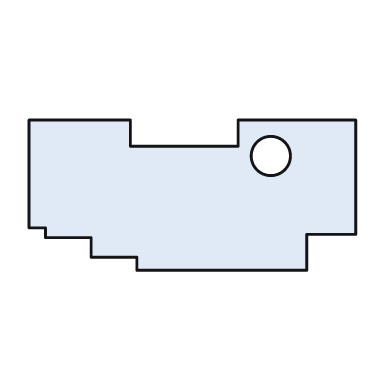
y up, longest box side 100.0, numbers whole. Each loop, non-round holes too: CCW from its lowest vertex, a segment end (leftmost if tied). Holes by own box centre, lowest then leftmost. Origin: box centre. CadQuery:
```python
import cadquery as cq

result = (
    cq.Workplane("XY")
    .moveTo(-17.0, -23.0)
    .lineTo(35.0, -23.0)
    .lineTo(35.0, -12.0)
    .lineTo(50.0, -12.0)
    .lineTo(50.0, 23.0)
    .lineTo(14.0, 23.0)
    .lineTo(14.0, 15.0)
    .lineTo(-19.0, 15.0)
    .lineTo(-19.0, 23.0)
    .lineTo(-50.0, 23.0)
    .lineTo(-50.0, -10.0)
    .lineTo(-45.0, -10.0)
    .lineTo(-45.0, -13.0)
    .lineTo(-31.0, -13.0)
    .lineTo(-31.0, -19.0)
    .lineTo(-17.0, -19.0)
    .close()
    .moveTo(24.0, 12.0)
    .circle(6.0)
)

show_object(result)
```